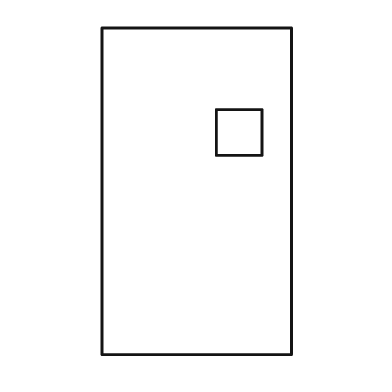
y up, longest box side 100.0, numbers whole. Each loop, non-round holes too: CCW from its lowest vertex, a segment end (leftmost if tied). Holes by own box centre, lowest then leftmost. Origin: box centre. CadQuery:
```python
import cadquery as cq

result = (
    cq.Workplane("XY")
    .moveTo(-29.0, -50.0)
    .lineTo(29.0, -50.0)
    .lineTo(29.0, 50.0)
    .lineTo(-29.0, 50.0)
    .close()
    .moveTo(6.0, 11.0)
    .lineTo(20.0, 11.0)
    .lineTo(20.0, 25.0)
    .lineTo(6.0, 25.0)
    .close()
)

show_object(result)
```